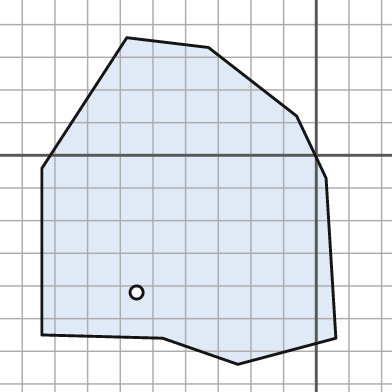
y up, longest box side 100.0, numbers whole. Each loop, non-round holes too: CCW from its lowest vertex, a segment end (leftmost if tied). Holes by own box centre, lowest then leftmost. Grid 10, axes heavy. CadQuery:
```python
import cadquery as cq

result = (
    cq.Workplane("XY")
    .moveTo(-24.0, -64.0)
    .lineTo(6.0, -56.0)
    .lineTo(3.0, -7.0)
    .lineTo(-6.0, 12.0)
    .lineTo(-33.0, 33.0)
    .lineTo(-58.0, 36.0)
    .lineTo(-84.0, -4.0)
    .lineTo(-84.0, -55.0)
    .lineTo(-47.0, -56.0)
    .close()
    .moveTo(-55.0, -42.0)
    .circle(2.0)
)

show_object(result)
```